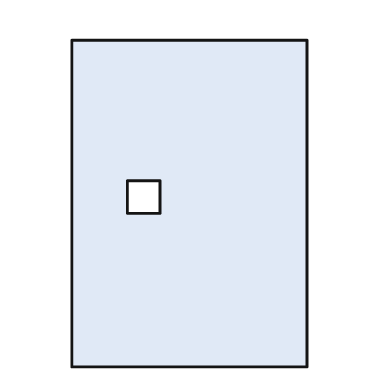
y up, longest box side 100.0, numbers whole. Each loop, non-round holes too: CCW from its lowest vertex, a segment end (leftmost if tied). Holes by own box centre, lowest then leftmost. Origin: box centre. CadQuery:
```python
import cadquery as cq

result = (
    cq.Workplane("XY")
    .moveTo(-36.0, -50.0)
    .lineTo(36.0, -50.0)
    .lineTo(36.0, 50.0)
    .lineTo(-36.0, 50.0)
    .close()
    .moveTo(-19.0, -3.0)
    .lineTo(-9.0, -3.0)
    .lineTo(-9.0, 7.0)
    .lineTo(-19.0, 7.0)
    .close()
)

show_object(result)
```